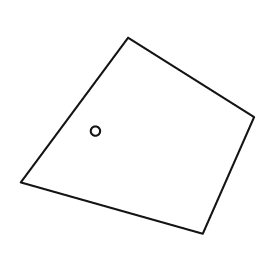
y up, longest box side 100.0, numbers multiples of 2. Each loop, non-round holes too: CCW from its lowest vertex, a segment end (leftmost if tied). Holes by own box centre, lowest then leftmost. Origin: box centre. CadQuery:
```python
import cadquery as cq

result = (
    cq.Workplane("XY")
    .moveTo(28.0, -42.0)
    .lineTo(50.0, 8.0)
    .lineTo(-4.0, 42.0)
    .lineTo(-50.0, -20.0)
    .close()
    .moveTo(-18.0, 2.0)
    .circle(2.0)
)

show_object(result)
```